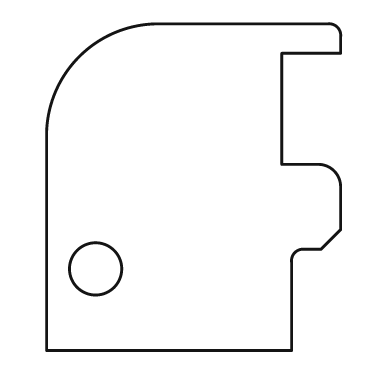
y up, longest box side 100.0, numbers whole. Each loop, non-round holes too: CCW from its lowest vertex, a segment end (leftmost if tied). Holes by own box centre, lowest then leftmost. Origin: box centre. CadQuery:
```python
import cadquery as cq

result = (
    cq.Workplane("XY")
    .moveTo(-45.0, -50.0)
    .lineTo(30.0, -50.0)
    .lineTo(30.0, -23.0)
    .threePointArc((31.0, -20.0), (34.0, -19.0))
    .lineTo(39.0, -19.0)
    .lineTo(45.0, -13.0)
    .lineTo(45.0, 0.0)
    .threePointArc((43.0, 5.0), (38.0, 7.0))
    .lineTo(27.0, 7.0)
    .lineTo(27.0, 41.0)
    .lineTo(45.0, 41.0)
    .lineTo(45.0, 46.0)
    .threePointArc((44.0, 49.0), (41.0, 50.0))
    .lineTo(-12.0, 50.0)
    .threePointArc((-35.0, 40.0), (-45.0, 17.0))
    .close()
    .moveTo(-30.0, -25.0)
    .circle(8.0)
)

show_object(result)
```